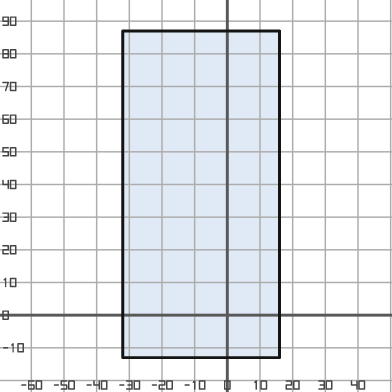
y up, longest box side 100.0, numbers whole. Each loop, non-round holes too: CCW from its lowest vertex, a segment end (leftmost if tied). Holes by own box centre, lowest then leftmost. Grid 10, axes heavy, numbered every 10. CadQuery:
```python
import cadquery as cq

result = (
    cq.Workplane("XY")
    .moveTo(-32.0, -13.0)
    .lineTo(16.0, -13.0)
    .lineTo(16.0, 87.0)
    .lineTo(-32.0, 87.0)
    .close()
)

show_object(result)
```